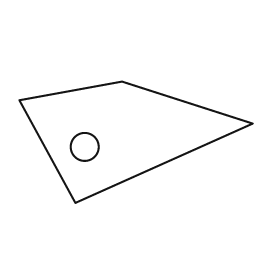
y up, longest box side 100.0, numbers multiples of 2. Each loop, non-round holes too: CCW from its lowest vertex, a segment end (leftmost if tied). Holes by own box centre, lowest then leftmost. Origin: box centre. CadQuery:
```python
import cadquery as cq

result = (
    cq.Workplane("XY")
    .moveTo(-26.0, -26.0)
    .lineTo(50.0, 8.0)
    .lineTo(-6.0, 26.0)
    .lineTo(-50.0, 18.0)
    .close()
    .moveTo(-22.0, -2.0)
    .circle(6.0)
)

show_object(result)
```